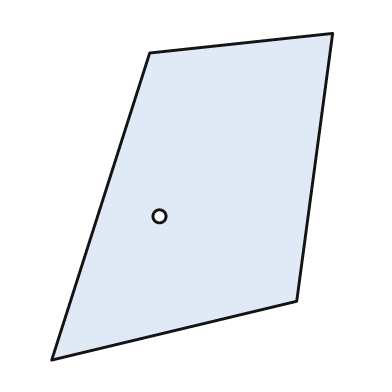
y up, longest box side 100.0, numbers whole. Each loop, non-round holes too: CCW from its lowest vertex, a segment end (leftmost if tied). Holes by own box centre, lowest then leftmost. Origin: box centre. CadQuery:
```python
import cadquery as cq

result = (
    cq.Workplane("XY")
    .moveTo(-43.0, -50.0)
    .lineTo(32.0, -32.0)
    .lineTo(43.0, 50.0)
    .lineTo(-13.0, 44.0)
    .close()
    .moveTo(-10.0, -6.0)
    .circle(2.0)
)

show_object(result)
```